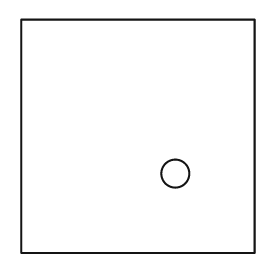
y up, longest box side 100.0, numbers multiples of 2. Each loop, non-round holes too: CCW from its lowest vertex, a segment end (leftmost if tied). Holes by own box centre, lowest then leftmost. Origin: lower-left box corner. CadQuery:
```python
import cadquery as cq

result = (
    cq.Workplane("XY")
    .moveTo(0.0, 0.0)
    .lineTo(100.0, 0.0)
    .lineTo(100.0, 100.0)
    .lineTo(0.0, 100.0)
    .close()
    .moveTo(66.0, 34.0)
    .circle(6.0)
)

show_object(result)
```